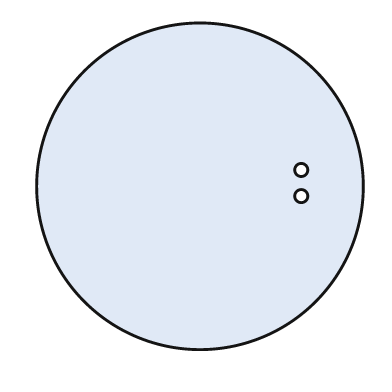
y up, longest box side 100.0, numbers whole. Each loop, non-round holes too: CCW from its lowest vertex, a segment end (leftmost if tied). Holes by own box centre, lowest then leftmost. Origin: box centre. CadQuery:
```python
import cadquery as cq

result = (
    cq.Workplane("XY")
    .moveTo(0.0, 0.0)
    .circle(50.0)
    .moveTo(31.0, -3.0)
    .circle(2.0)
    .moveTo(31.0, 5.0)
    .circle(2.0)
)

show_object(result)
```